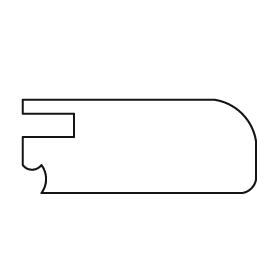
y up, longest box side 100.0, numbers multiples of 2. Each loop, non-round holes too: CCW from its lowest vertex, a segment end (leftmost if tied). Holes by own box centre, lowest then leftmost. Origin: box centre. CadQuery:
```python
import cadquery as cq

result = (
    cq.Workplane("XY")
    .moveTo(-42.0, -20.0)
    .lineTo(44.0, -20.0)
    .threePointArc((48.0, -18.0), (50.0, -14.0))
    .lineTo(50.0, 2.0)
    .threePointArc((44.0, 14.0), (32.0, 20.0))
    .lineTo(-50.0, 20.0)
    .lineTo(-50.0, 14.0)
    .lineTo(-28.0, 14.0)
    .lineTo(-28.0, 4.0)
    .lineTo(-50.0, 4.0)
    .lineTo(-50.0, -8.0)
    .threePointArc((-46.0, -10.0), (-42.0, -8.0))
    .threePointArc((-40.0, -14.0), (-42.0, -20.0))
    .close()
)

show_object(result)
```